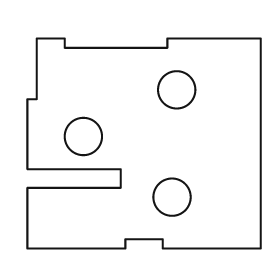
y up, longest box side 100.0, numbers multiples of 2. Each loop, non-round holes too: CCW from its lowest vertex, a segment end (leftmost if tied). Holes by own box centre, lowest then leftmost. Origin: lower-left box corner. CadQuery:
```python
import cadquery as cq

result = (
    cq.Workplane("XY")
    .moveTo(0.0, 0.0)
    .lineTo(42.0, 0.0)
    .lineTo(42.0, 4.0)
    .lineTo(58.0, 4.0)
    .lineTo(58.0, 0.0)
    .lineTo(100.0, 0.0)
    .lineTo(100.0, 90.0)
    .lineTo(60.0, 90.0)
    .lineTo(60.0, 86.0)
    .lineTo(16.0, 86.0)
    .lineTo(16.0, 90.0)
    .lineTo(4.0, 90.0)
    .lineTo(4.0, 64.0)
    .lineTo(0.0, 64.0)
    .lineTo(0.0, 34.0)
    .lineTo(40.0, 34.0)
    .lineTo(40.0, 26.0)
    .lineTo(0.0, 26.0)
    .close()
    .moveTo(62.0, 22.0)
    .circle(8.0)
    .moveTo(24.0, 48.0)
    .circle(8.0)
    .moveTo(64.0, 68.0)
    .circle(8.0)
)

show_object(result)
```